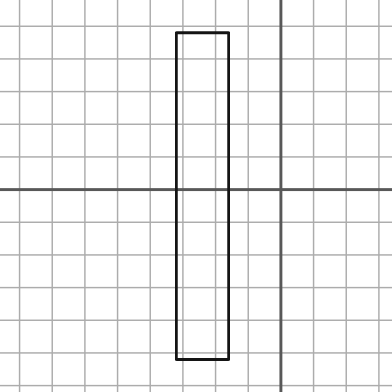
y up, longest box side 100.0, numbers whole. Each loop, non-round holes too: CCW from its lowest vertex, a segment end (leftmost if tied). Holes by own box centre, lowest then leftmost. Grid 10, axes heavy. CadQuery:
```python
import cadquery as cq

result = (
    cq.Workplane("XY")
    .moveTo(-32.0, -52.0)
    .lineTo(-16.0, -52.0)
    .lineTo(-16.0, 48.0)
    .lineTo(-32.0, 48.0)
    .close()
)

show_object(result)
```